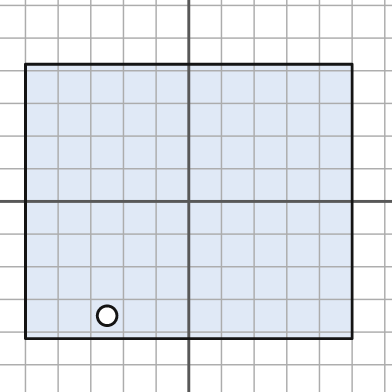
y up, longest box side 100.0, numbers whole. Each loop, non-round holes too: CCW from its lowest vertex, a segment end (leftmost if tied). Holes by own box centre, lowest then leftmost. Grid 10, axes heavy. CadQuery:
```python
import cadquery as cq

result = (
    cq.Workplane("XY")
    .moveTo(-50.0, -42.0)
    .lineTo(50.0, -42.0)
    .lineTo(50.0, 42.0)
    .lineTo(-50.0, 42.0)
    .close()
    .moveTo(-25.0, -35.0)
    .circle(3.0)
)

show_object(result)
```